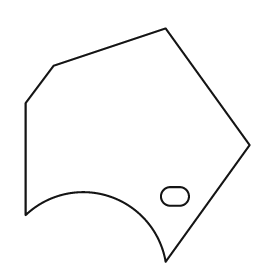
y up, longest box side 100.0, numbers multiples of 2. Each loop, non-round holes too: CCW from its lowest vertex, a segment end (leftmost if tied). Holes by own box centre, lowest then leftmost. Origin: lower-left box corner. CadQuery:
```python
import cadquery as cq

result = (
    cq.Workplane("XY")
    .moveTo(60.0, 0.0)
    .lineTo(96.0, 50.0)
    .lineTo(60.0, 100.0)
    .lineTo(12.0, 84.0)
    .lineTo(0.0, 68.0)
    .lineTo(0.0, 20.0)
    .threePointArc((36.0, 28.0), (60.0, 0.0))
    .close()
    .moveTo(62.0, 24.0)
    .lineTo(66.0, 24.0)
    .threePointArc((70.0, 28.0), (66.0, 32.0))
    .lineTo(62.0, 32.0)
    .threePointArc((58.0, 28.0), (62.0, 24.0))
    .close()
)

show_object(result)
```